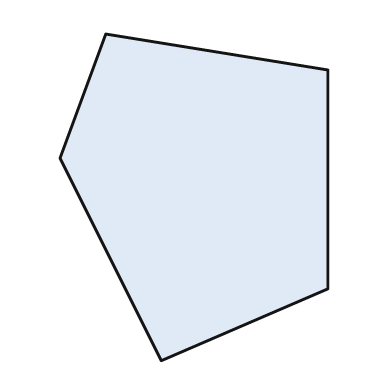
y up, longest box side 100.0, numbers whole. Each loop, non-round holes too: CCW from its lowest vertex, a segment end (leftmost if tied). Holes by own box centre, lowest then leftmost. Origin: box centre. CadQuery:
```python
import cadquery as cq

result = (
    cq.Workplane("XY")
    .moveTo(-10.0, -50.0)
    .lineTo(41.0, -28.0)
    .lineTo(41.0, 39.0)
    .lineTo(-27.0, 50.0)
    .lineTo(-41.0, 12.0)
    .close()
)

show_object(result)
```